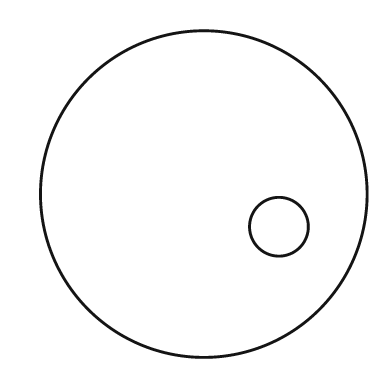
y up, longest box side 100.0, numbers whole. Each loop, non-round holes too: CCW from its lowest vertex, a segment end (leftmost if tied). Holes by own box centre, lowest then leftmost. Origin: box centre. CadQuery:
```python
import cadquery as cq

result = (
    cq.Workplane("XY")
    .moveTo(0.0, 0.0)
    .circle(50.0)
    .moveTo(23.0, -10.0)
    .circle(9.0)
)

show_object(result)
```